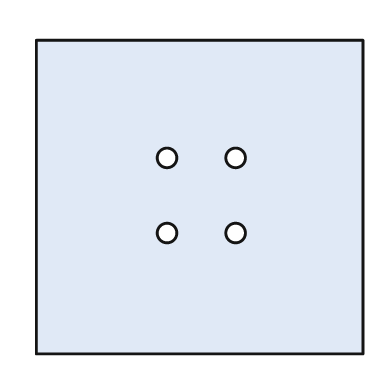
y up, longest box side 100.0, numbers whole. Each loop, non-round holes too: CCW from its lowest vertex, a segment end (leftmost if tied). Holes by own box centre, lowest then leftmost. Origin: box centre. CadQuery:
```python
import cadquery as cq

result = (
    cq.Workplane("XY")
    .moveTo(-50.0, -48.0)
    .lineTo(50.0, -48.0)
    .lineTo(50.0, 48.0)
    .lineTo(-50.0, 48.0)
    .close()
    .moveTo(-10.0, -11.0)
    .circle(3.0)
    .moveTo(11.0, -11.0)
    .circle(3.0)
    .moveTo(-10.0, 12.0)
    .circle(3.0)
    .moveTo(11.0, 12.0)
    .circle(3.0)
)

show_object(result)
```